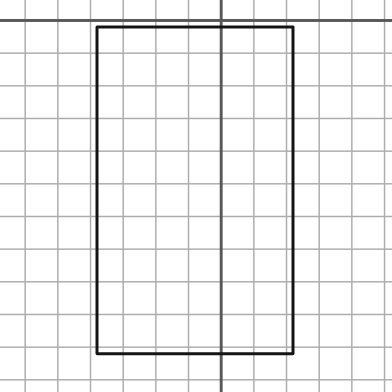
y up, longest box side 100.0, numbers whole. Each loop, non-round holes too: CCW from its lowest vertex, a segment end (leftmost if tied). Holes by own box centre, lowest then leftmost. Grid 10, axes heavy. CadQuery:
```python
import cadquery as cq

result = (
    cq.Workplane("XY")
    .moveTo(-38.0, -102.0)
    .lineTo(22.0, -102.0)
    .lineTo(22.0, -2.0)
    .lineTo(-38.0, -2.0)
    .close()
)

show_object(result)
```